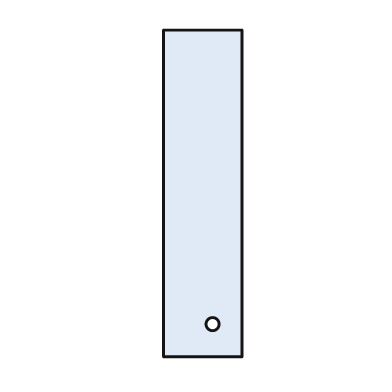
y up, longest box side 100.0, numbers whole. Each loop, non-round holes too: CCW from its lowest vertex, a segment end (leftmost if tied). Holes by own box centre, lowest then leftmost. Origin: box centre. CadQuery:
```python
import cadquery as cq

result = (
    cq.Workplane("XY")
    .moveTo(-12.0, -50.0)
    .lineTo(12.0, -50.0)
    .lineTo(12.0, 50.0)
    .lineTo(-12.0, 50.0)
    .close()
    .moveTo(3.0, -40.0)
    .circle(2.0)
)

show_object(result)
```